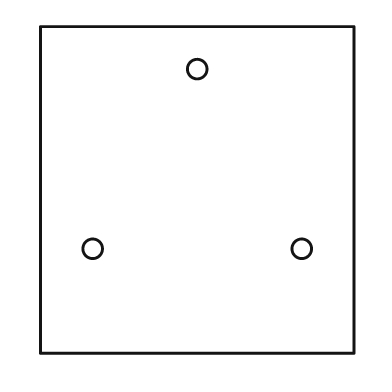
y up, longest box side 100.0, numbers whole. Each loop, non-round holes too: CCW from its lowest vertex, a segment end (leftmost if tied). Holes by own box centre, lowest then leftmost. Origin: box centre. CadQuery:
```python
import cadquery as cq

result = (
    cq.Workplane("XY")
    .moveTo(-48.0, -50.0)
    .lineTo(48.0, -50.0)
    .lineTo(48.0, 50.0)
    .lineTo(-48.0, 50.0)
    .close()
    .moveTo(-32.0, -18.0)
    .circle(3.0)
    .moveTo(32.0, -18.0)
    .circle(3.0)
    .moveTo(0.0, 37.0)
    .circle(3.0)
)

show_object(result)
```